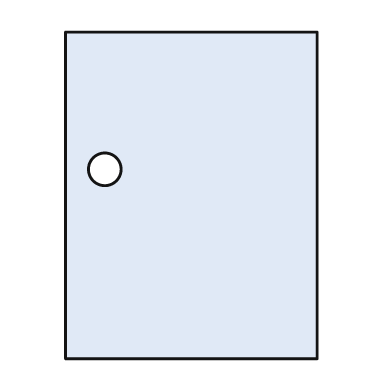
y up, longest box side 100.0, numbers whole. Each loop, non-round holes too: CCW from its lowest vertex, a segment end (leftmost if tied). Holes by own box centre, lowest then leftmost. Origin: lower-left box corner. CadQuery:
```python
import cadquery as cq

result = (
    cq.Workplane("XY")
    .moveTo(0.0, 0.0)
    .lineTo(77.0, 0.0)
    .lineTo(77.0, 100.0)
    .lineTo(0.0, 100.0)
    .close()
    .moveTo(12.0, 58.0)
    .circle(5.0)
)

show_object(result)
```